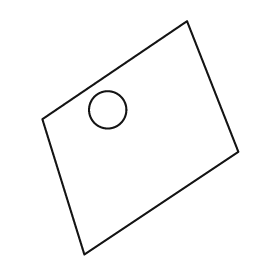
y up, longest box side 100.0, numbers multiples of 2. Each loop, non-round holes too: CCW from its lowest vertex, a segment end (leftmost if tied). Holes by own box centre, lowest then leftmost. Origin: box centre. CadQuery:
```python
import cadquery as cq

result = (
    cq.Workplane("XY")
    .moveTo(-24.0, -50.0)
    .lineTo(42.0, -6.0)
    .lineTo(20.0, 50.0)
    .lineTo(-42.0, 8.0)
    .close()
    .moveTo(-14.0, 12.0)
    .circle(8.0)
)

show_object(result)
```